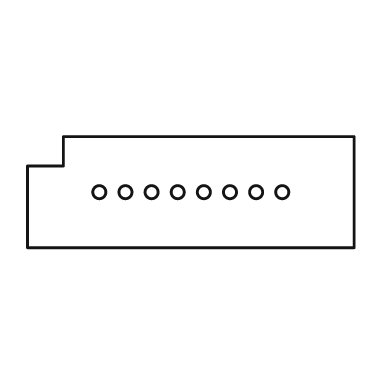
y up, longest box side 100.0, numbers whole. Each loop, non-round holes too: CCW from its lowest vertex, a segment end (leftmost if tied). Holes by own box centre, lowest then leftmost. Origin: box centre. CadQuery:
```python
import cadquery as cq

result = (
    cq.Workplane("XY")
    .moveTo(-50.0, -17.0)
    .lineTo(50.0, -17.0)
    .lineTo(50.0, 17.0)
    .lineTo(-39.0, 17.0)
    .lineTo(-39.0, 8.0)
    .lineTo(-50.0, 8.0)
    .close()
    .moveTo(-28.0, 0.0)
    .circle(2.0)
    .moveTo(-20.0, 0.0)
    .circle(2.0)
    .moveTo(-12.0, 0.0)
    .circle(2.0)
    .moveTo(-4.0, 0.0)
    .circle(2.0)
    .moveTo(4.0, 0.0)
    .circle(2.0)
    .moveTo(12.0, 0.0)
    .circle(2.0)
    .moveTo(20.0, 0.0)
    .circle(2.0)
    .moveTo(28.0, 0.0)
    .circle(2.0)
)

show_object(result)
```